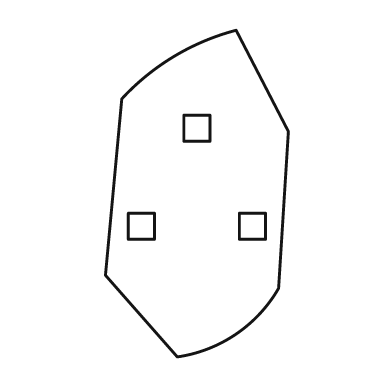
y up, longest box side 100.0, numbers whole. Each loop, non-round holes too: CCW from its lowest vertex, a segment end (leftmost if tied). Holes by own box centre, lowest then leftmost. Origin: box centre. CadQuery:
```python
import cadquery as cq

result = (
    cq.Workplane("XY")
    .moveTo(-6.0, -50.0)
    .threePointArc((12.0, -43.0), (25.0, -29.0))
    .lineTo(28.0, 19.0)
    .lineTo(12.0, 50.0)
    .threePointArc((-7.0, 42.0), (-23.0, 29.0))
    .lineTo(-28.0, -25.0)
    .close()
    .moveTo(-21.0, -14.0)
    .lineTo(-13.0, -14.0)
    .lineTo(-13.0, -6.0)
    .lineTo(-21.0, -6.0)
    .close()
    .moveTo(13.0, -14.0)
    .lineTo(21.0, -14.0)
    .lineTo(21.0, -6.0)
    .lineTo(13.0, -6.0)
    .close()
    .moveTo(-4.0, 16.0)
    .lineTo(4.0, 16.0)
    .lineTo(4.0, 24.0)
    .lineTo(-4.0, 24.0)
    .close()
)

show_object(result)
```